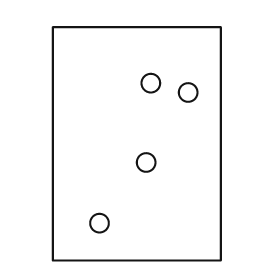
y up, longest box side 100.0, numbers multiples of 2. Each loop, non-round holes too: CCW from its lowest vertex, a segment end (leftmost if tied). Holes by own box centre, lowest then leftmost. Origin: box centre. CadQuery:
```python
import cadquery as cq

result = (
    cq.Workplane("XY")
    .moveTo(-36.0, -50.0)
    .lineTo(36.0, -50.0)
    .lineTo(36.0, 50.0)
    .lineTo(-36.0, 50.0)
    .close()
    .moveTo(-16.0, -34.0)
    .circle(4.0)
    .moveTo(4.0, -8.0)
    .circle(4.0)
    .moveTo(22.0, 22.0)
    .circle(4.0)
    .moveTo(6.0, 26.0)
    .circle(4.0)
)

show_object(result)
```